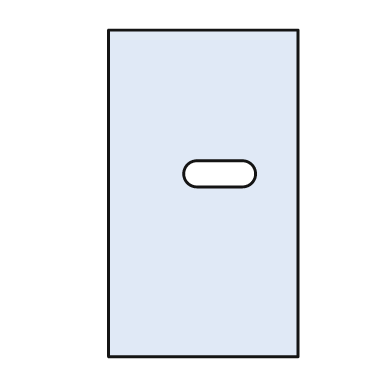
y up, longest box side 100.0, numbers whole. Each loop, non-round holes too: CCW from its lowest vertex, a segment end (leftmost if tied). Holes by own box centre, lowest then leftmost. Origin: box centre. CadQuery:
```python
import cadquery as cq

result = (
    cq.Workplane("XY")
    .moveTo(-29.0, -50.0)
    .lineTo(29.0, -50.0)
    .lineTo(29.0, 50.0)
    .lineTo(-29.0, 50.0)
    .close()
    .moveTo(-2.0, 2.0)
    .lineTo(12.0, 2.0)
    .threePointArc((16.0, 6.0), (12.0, 10.0))
    .lineTo(-2.0, 10.0)
    .threePointArc((-6.0, 6.0), (-2.0, 2.0))
    .close()
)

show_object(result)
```